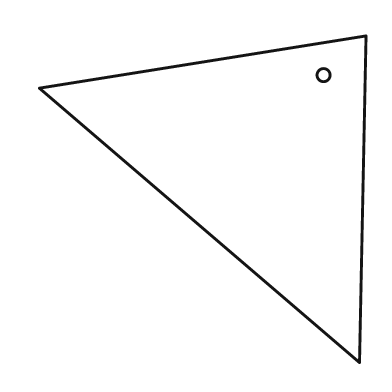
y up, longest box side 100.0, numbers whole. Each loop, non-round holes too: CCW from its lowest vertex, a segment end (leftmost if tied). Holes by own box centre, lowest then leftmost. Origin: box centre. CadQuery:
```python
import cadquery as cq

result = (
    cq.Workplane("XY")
    .moveTo(48.0, -50.0)
    .lineTo(50.0, 50.0)
    .lineTo(-50.0, 34.0)
    .close()
    .moveTo(37.0, 38.0)
    .circle(2.0)
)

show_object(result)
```